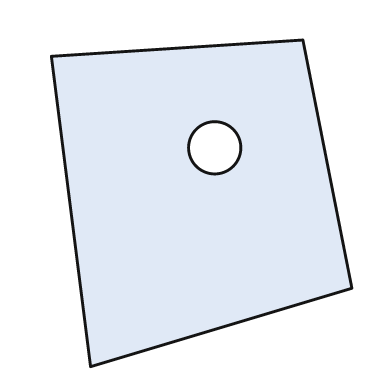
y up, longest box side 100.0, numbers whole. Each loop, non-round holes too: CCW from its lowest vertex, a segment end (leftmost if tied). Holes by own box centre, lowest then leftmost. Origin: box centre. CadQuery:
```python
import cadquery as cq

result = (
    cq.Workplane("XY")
    .moveTo(-34.0, -50.0)
    .lineTo(46.0, -26.0)
    .lineTo(31.0, 50.0)
    .lineTo(-46.0, 45.0)
    .close()
    .moveTo(4.0, 17.0)
    .circle(8.0)
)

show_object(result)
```